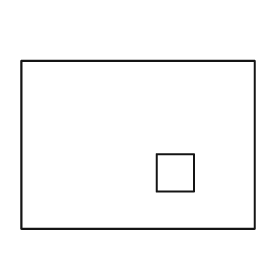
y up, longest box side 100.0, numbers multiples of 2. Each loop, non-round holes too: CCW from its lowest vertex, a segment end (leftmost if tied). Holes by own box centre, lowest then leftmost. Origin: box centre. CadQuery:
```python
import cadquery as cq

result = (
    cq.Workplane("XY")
    .moveTo(-50.0, -36.0)
    .lineTo(50.0, -36.0)
    .lineTo(50.0, 36.0)
    .lineTo(-50.0, 36.0)
    .close()
    .moveTo(8.0, -20.0)
    .lineTo(24.0, -20.0)
    .lineTo(24.0, -4.0)
    .lineTo(8.0, -4.0)
    .close()
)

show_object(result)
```